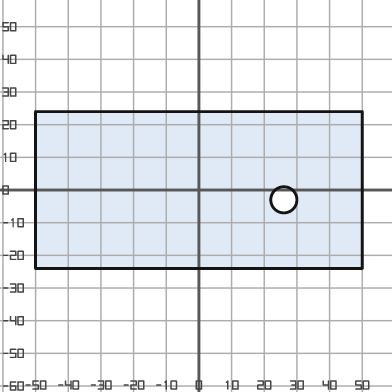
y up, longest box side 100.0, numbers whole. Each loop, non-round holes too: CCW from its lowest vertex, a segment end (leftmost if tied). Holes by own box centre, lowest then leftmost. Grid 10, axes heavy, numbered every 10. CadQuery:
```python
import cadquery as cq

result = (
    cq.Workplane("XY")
    .moveTo(-50.0, -24.0)
    .lineTo(50.0, -24.0)
    .lineTo(50.0, 24.0)
    .lineTo(-50.0, 24.0)
    .close()
    .moveTo(26.0, -3.0)
    .circle(4.0)
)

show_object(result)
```